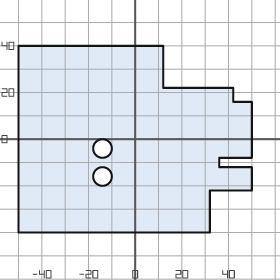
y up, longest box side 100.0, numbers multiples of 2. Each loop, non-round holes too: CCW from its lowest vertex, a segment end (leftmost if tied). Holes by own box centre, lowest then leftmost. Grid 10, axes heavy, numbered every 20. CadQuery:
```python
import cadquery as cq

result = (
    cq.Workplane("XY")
    .moveTo(-50.0, -40.0)
    .lineTo(32.0, -40.0)
    .lineTo(32.0, -22.0)
    .lineTo(50.0, -22.0)
    .lineTo(50.0, -12.0)
    .lineTo(36.0, -12.0)
    .lineTo(36.0, -8.0)
    .lineTo(50.0, -8.0)
    .lineTo(50.0, 16.0)
    .lineTo(42.0, 16.0)
    .lineTo(42.0, 22.0)
    .lineTo(12.0, 22.0)
    .lineTo(12.0, 40.0)
    .lineTo(-50.0, 40.0)
    .close()
    .moveTo(-14.0, -16.0)
    .circle(4.0)
    .moveTo(-14.0, -4.0)
    .circle(4.0)
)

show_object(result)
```